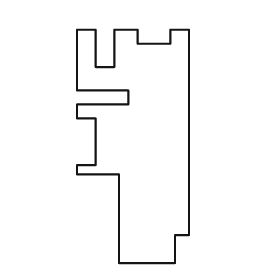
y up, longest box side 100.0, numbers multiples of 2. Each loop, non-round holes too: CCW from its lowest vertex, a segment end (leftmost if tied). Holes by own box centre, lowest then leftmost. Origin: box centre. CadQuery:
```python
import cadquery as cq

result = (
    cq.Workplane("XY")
    .moveTo(-6.0, -50.0)
    .lineTo(18.0, -50.0)
    .lineTo(18.0, -38.0)
    .lineTo(24.0, -38.0)
    .lineTo(24.0, 50.0)
    .lineTo(16.0, 50.0)
    .lineTo(16.0, 44.0)
    .lineTo(2.0, 44.0)
    .lineTo(2.0, 50.0)
    .lineTo(-8.0, 50.0)
    .lineTo(-8.0, 34.0)
    .lineTo(-16.0, 34.0)
    .lineTo(-16.0, 50.0)
    .lineTo(-24.0, 50.0)
    .lineTo(-24.0, 24.0)
    .lineTo(-2.0, 24.0)
    .lineTo(-2.0, 18.0)
    .lineTo(-24.0, 18.0)
    .lineTo(-24.0, 12.0)
    .lineTo(-16.0, 12.0)
    .lineTo(-16.0, -8.0)
    .lineTo(-24.0, -8.0)
    .lineTo(-24.0, -12.0)
    .lineTo(-6.0, -12.0)
    .close()
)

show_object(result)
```